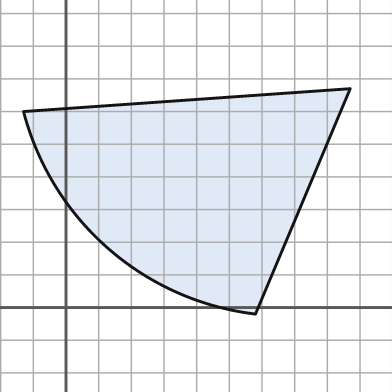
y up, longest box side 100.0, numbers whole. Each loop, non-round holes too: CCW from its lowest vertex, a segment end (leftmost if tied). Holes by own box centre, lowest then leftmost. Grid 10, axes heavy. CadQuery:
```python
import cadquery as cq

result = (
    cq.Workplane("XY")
    .moveTo(58.0, -2.0)
    .lineTo(87.0, 67.0)
    .lineTo(-13.0, 60.0)
    .threePointArc((13.0, 18.0), (58.0, -2.0))
    .close()
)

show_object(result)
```